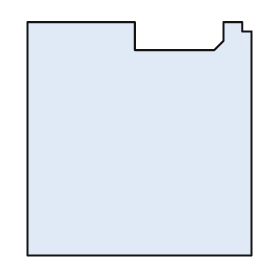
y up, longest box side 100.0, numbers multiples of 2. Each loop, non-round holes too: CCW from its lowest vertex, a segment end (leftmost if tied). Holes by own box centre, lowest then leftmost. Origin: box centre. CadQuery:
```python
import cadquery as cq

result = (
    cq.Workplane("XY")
    .moveTo(-48.0, -50.0)
    .lineTo(48.0, -50.0)
    .lineTo(48.0, 46.0)
    .lineTo(44.0, 46.0)
    .lineTo(44.0, 50.0)
    .lineTo(36.0, 50.0)
    .lineTo(36.0, 42.0)
    .lineTo(32.0, 38.0)
    .lineTo(-2.0, 38.0)
    .lineTo(-2.0, 50.0)
    .lineTo(-48.0, 50.0)
    .close()
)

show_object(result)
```